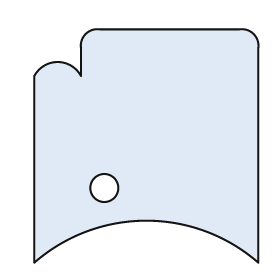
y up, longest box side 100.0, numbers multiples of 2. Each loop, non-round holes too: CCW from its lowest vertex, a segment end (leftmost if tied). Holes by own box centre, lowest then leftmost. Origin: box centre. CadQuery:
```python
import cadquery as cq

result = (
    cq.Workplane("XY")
    .moveTo(-48.0, -50.0)
    .threePointArc((0.0, -32.0), (48.0, -50.0))
    .lineTo(48.0, 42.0)
    .threePointArc((46.0, 48.0), (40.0, 50.0))
    .lineTo(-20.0, 50.0)
    .threePointArc((-26.0, 48.0), (-28.0, 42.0))
    .lineTo(-28.0, 30.0)
    .threePointArc((-38.0, 36.0), (-48.0, 30.0))
    .close()
    .moveTo(-18.0, -18.0)
    .circle(6.0)
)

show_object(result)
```